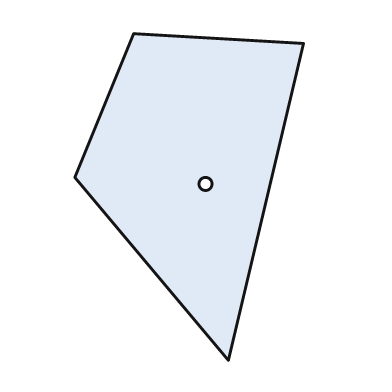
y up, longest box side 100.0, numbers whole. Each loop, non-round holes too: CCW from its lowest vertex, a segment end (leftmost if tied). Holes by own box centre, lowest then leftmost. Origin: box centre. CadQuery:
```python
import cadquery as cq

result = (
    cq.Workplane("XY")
    .moveTo(12.0, -50.0)
    .lineTo(35.0, 47.0)
    .lineTo(-17.0, 50.0)
    .lineTo(-35.0, 6.0)
    .close()
    .moveTo(5.0, 4.0)
    .circle(2.0)
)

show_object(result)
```